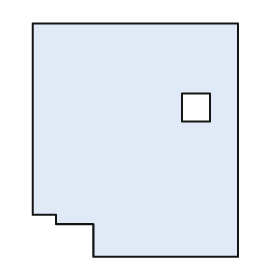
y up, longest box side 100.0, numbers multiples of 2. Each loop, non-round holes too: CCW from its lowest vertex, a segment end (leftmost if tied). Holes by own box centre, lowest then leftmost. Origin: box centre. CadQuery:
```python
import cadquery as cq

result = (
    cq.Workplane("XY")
    .moveTo(-18.0, -50.0)
    .lineTo(44.0, -50.0)
    .lineTo(44.0, 50.0)
    .lineTo(-44.0, 50.0)
    .lineTo(-44.0, -32.0)
    .lineTo(-34.0, -32.0)
    .lineTo(-34.0, -36.0)
    .lineTo(-18.0, -36.0)
    .close()
    .moveTo(20.0, 8.0)
    .lineTo(32.0, 8.0)
    .lineTo(32.0, 20.0)
    .lineTo(20.0, 20.0)
    .close()
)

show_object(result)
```